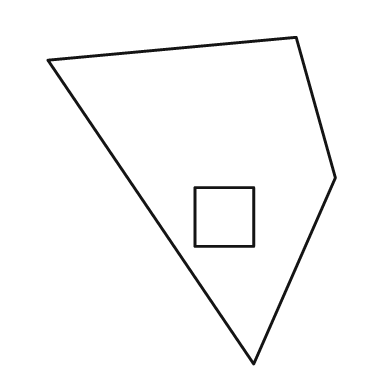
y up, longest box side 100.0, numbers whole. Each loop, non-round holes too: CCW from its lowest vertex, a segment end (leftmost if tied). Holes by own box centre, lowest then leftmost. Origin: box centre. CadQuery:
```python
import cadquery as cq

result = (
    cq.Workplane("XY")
    .moveTo(19.0, -50.0)
    .lineTo(44.0, 7.0)
    .lineTo(32.0, 50.0)
    .lineTo(-44.0, 43.0)
    .close()
    .moveTo(1.0, -14.0)
    .lineTo(19.0, -14.0)
    .lineTo(19.0, 4.0)
    .lineTo(1.0, 4.0)
    .close()
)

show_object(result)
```